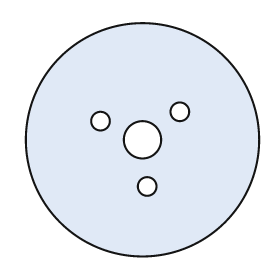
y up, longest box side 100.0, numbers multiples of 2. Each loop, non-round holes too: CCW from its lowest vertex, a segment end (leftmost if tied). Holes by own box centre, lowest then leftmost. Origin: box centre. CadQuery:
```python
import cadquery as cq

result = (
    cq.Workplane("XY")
    .moveTo(0.0, 0.0)
    .circle(50.0)
    .moveTo(2.0, -20.0)
    .circle(4.0)
    .moveTo(0.0, 0.0)
    .circle(8.0)
    .moveTo(-18.0, 8.0)
    .circle(4.0)
    .moveTo(16.0, 12.0)
    .circle(4.0)
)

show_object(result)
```